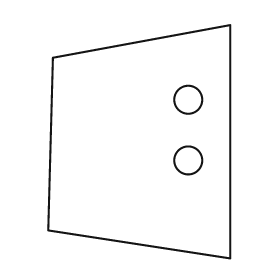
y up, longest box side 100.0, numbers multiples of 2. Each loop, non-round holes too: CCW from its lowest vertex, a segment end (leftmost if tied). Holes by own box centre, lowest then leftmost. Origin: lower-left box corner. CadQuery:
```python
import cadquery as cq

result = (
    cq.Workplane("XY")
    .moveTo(78.0, 0.0)
    .lineTo(78.0, 100.0)
    .lineTo(2.0, 86.0)
    .lineTo(0.0, 12.0)
    .close()
    .moveTo(60.0, 42.0)
    .circle(6.0)
    .moveTo(60.0, 68.0)
    .circle(6.0)
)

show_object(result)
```